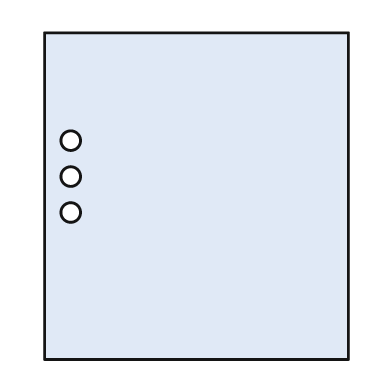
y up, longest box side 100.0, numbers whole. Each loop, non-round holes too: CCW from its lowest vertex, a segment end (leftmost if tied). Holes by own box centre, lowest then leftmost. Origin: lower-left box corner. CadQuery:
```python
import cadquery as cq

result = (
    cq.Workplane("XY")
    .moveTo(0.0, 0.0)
    .lineTo(93.0, 0.0)
    .lineTo(93.0, 100.0)
    .lineTo(0.0, 100.0)
    .close()
    .moveTo(8.0, 45.0)
    .circle(3.0)
    .moveTo(8.0, 56.0)
    .circle(3.0)
    .moveTo(8.0, 67.0)
    .circle(3.0)
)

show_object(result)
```